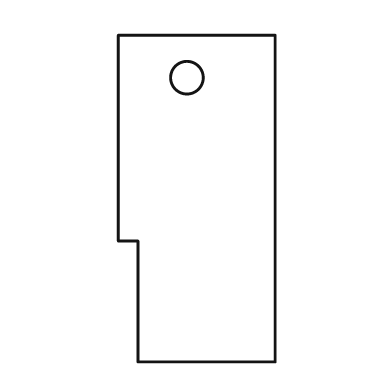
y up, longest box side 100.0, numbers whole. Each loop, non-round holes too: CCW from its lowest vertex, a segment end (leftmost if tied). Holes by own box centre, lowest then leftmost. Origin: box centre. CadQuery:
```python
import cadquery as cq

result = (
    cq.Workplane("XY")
    .moveTo(-18.0, -50.0)
    .lineTo(24.0, -50.0)
    .lineTo(24.0, 50.0)
    .lineTo(-24.0, 50.0)
    .lineTo(-24.0, -13.0)
    .lineTo(-18.0, -13.0)
    .close()
    .moveTo(-3.0, 37.0)
    .circle(5.0)
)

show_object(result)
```